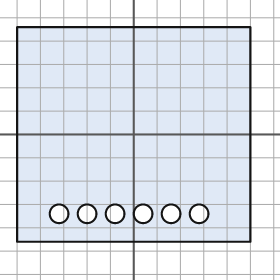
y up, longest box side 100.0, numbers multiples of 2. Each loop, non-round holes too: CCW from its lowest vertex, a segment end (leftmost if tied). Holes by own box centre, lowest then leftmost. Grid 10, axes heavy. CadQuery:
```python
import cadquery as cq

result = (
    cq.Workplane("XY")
    .moveTo(-50.0, -46.0)
    .lineTo(50.0, -46.0)
    .lineTo(50.0, 46.0)
    .lineTo(-50.0, 46.0)
    .close()
    .moveTo(-32.0, -34.0)
    .circle(4.0)
    .moveTo(-20.0, -34.0)
    .circle(4.0)
    .moveTo(-8.0, -34.0)
    .circle(4.0)
    .moveTo(4.0, -34.0)
    .circle(4.0)
    .moveTo(16.0, -34.0)
    .circle(4.0)
    .moveTo(28.0, -34.0)
    .circle(4.0)
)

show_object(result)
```